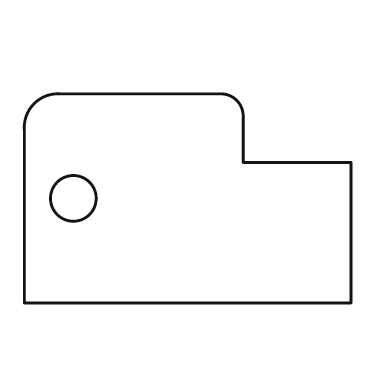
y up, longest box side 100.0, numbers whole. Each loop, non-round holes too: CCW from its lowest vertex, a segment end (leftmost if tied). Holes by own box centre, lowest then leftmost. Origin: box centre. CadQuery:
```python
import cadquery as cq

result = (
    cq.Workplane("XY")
    .moveTo(-50.0, -32.0)
    .lineTo(50.0, -32.0)
    .lineTo(50.0, 11.0)
    .lineTo(17.0, 11.0)
    .lineTo(17.0, 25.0)
    .threePointArc((15.0, 30.0), (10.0, 32.0))
    .lineTo(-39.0, 32.0)
    .threePointArc((-47.0, 29.0), (-50.0, 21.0))
    .close()
    .moveTo(-35.0, 0.0)
    .circle(7.0)
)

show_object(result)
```